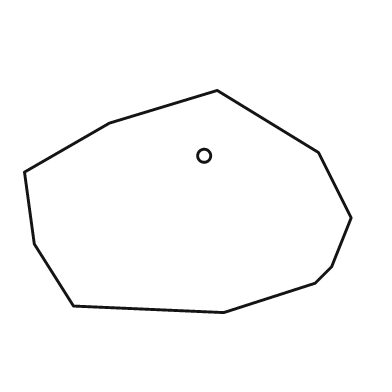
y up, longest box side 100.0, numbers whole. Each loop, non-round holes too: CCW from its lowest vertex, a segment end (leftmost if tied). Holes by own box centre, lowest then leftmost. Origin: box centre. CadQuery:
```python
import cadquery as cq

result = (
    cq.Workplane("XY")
    .moveTo(11.0, -34.0)
    .lineTo(39.0, -25.0)
    .lineTo(44.0, -20.0)
    .lineTo(50.0, -5.0)
    .lineTo(40.0, 15.0)
    .lineTo(9.0, 34.0)
    .lineTo(-24.0, 24.0)
    .lineTo(-50.0, 9.0)
    .lineTo(-47.0, -13.0)
    .lineTo(-35.0, -32.0)
    .close()
    .moveTo(5.0, 14.0)
    .circle(2.0)
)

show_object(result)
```